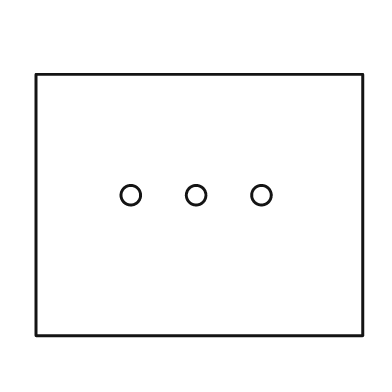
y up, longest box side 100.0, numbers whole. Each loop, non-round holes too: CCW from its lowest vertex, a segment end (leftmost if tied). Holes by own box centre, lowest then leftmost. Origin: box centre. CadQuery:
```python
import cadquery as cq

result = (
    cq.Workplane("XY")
    .moveTo(-50.0, -40.0)
    .lineTo(50.0, -40.0)
    .lineTo(50.0, 40.0)
    .lineTo(-50.0, 40.0)
    .close()
    .moveTo(-21.0, 3.0)
    .circle(3.0)
    .moveTo(-1.0, 3.0)
    .circle(3.0)
    .moveTo(19.0, 3.0)
    .circle(3.0)
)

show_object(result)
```